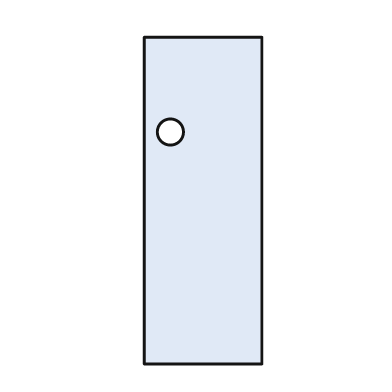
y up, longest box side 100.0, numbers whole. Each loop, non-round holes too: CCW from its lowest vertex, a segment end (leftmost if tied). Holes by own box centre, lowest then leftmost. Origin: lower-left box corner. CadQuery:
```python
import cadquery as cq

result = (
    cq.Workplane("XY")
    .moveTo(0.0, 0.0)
    .lineTo(36.0, 0.0)
    .lineTo(36.0, 100.0)
    .lineTo(0.0, 100.0)
    .close()
    .moveTo(8.0, 71.0)
    .circle(4.0)
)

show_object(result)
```